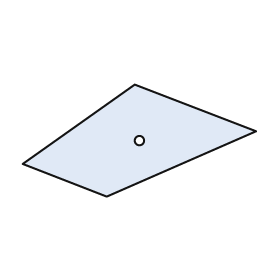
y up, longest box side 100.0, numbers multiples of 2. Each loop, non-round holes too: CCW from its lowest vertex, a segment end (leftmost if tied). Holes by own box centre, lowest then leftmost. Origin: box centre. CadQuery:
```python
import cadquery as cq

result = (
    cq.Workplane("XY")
    .moveTo(-14.0, -24.0)
    .lineTo(50.0, 4.0)
    .lineTo(-2.0, 24.0)
    .lineTo(-50.0, -10.0)
    .close()
    .moveTo(0.0, 0.0)
    .circle(2.0)
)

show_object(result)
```